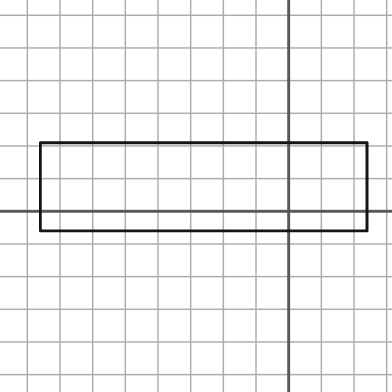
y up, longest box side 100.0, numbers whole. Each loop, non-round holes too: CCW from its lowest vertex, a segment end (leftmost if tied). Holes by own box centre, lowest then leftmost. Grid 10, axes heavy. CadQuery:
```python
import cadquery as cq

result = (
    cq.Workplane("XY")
    .moveTo(-76.0, -6.0)
    .lineTo(24.0, -6.0)
    .lineTo(24.0, 21.0)
    .lineTo(-76.0, 21.0)
    .close()
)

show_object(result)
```